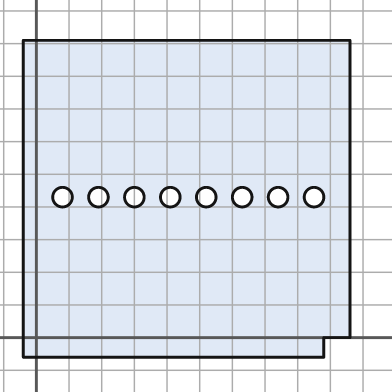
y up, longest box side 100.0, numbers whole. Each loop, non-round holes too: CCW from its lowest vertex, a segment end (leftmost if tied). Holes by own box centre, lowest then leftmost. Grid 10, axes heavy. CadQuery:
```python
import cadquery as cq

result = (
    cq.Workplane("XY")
    .moveTo(-4.0, -6.0)
    .lineTo(88.0, -6.0)
    .lineTo(88.0, 0.0)
    .lineTo(96.0, 0.0)
    .lineTo(96.0, 91.0)
    .lineTo(-4.0, 91.0)
    .close()
    .moveTo(8.0, 43.0)
    .circle(3.0)
    .moveTo(19.0, 43.0)
    .circle(3.0)
    .moveTo(30.0, 43.0)
    .circle(3.0)
    .moveTo(41.0, 43.0)
    .circle(3.0)
    .moveTo(52.0, 43.0)
    .circle(3.0)
    .moveTo(63.0, 43.0)
    .circle(3.0)
    .moveTo(74.0, 43.0)
    .circle(3.0)
    .moveTo(85.0, 43.0)
    .circle(3.0)
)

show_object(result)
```